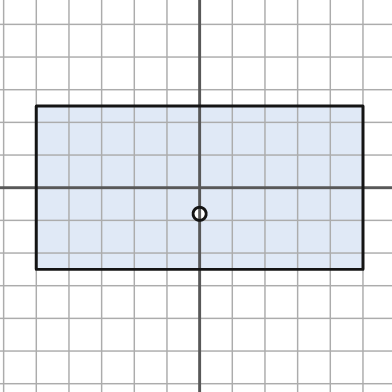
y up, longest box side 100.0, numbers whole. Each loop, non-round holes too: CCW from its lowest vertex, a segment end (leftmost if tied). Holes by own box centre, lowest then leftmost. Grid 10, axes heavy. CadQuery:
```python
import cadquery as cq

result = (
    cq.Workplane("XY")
    .moveTo(-50.0, -25.0)
    .lineTo(50.0, -25.0)
    .lineTo(50.0, 25.0)
    .lineTo(-50.0, 25.0)
    .close()
    .moveTo(0.0, -8.0)
    .circle(2.0)
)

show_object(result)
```